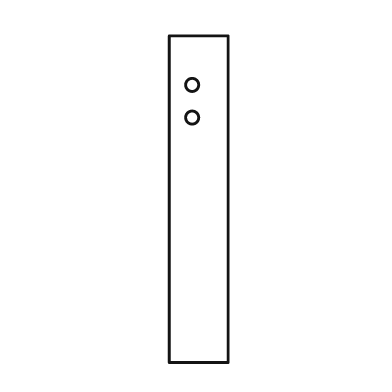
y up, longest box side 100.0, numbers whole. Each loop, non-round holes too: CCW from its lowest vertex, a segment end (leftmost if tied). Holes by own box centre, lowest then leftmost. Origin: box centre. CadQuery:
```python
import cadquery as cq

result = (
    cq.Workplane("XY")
    .moveTo(-9.0, -50.0)
    .lineTo(9.0, -50.0)
    .lineTo(9.0, 50.0)
    .lineTo(-9.0, 50.0)
    .close()
    .moveTo(-2.0, 25.0)
    .circle(2.0)
    .moveTo(-2.0, 35.0)
    .circle(2.0)
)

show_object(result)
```